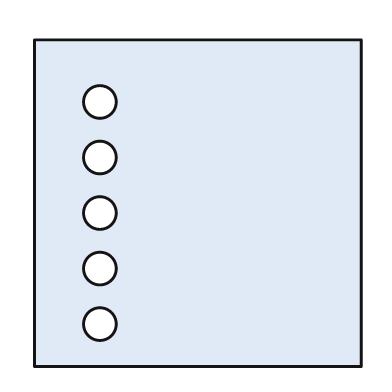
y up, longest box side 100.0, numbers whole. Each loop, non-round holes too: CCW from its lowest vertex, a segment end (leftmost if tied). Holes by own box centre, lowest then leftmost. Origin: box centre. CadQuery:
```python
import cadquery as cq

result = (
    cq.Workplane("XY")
    .moveTo(-50.0, -50.0)
    .lineTo(50.0, -50.0)
    .lineTo(50.0, 50.0)
    .lineTo(-50.0, 50.0)
    .close()
    .moveTo(-30.0, -37.0)
    .circle(5.0)
    .moveTo(-30.0, -20.0)
    .circle(5.0)
    .moveTo(-30.0, -3.0)
    .circle(5.0)
    .moveTo(-30.0, 14.0)
    .circle(5.0)
    .moveTo(-30.0, 31.0)
    .circle(5.0)
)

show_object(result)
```